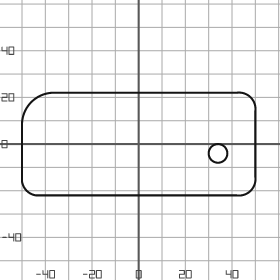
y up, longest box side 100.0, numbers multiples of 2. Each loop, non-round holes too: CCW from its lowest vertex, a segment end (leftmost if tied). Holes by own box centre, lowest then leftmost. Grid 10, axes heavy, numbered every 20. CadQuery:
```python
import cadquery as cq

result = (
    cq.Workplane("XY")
    .moveTo(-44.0, -22.0)
    .lineTo(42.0, -22.0)
    .threePointArc((48.0, -20.0), (50.0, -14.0))
    .lineTo(50.0, 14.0)
    .threePointArc((48.0, 20.0), (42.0, 22.0))
    .lineTo(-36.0, 22.0)
    .threePointArc((-46.0, 18.0), (-50.0, 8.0))
    .lineTo(-50.0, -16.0)
    .threePointArc((-48.0, -20.0), (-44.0, -22.0))
    .close()
    .moveTo(34.0, -4.0)
    .circle(4.0)
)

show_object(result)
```